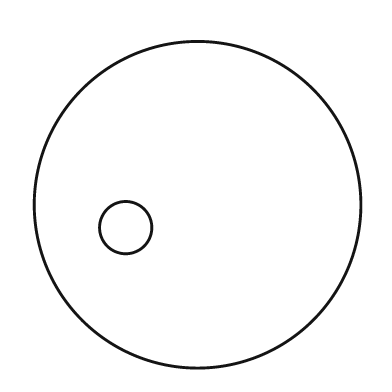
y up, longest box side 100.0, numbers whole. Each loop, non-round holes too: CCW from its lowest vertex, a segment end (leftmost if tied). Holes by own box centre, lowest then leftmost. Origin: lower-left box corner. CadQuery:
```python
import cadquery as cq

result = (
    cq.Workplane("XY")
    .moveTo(50.0, 50.0)
    .circle(50.0)
    .moveTo(28.0, 43.0)
    .circle(8.0)
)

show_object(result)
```